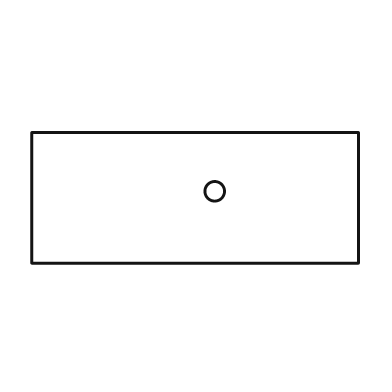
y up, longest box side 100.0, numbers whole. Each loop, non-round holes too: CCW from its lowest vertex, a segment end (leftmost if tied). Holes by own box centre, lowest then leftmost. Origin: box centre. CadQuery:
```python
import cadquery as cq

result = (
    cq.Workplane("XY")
    .moveTo(-50.0, -20.0)
    .lineTo(50.0, -20.0)
    .lineTo(50.0, 20.0)
    .lineTo(-50.0, 20.0)
    .close()
    .moveTo(6.0, 2.0)
    .circle(3.0)
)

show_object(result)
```